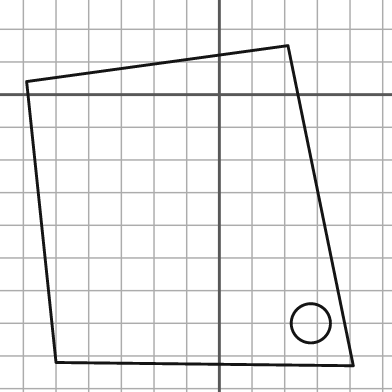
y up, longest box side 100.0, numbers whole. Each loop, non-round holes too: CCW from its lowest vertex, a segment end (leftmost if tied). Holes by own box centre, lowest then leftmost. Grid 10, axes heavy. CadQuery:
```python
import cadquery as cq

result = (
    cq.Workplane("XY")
    .moveTo(41.0, -83.0)
    .lineTo(21.0, 15.0)
    .lineTo(-59.0, 4.0)
    .lineTo(-50.0, -82.0)
    .close()
    .moveTo(28.0, -70.0)
    .circle(6.0)
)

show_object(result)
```